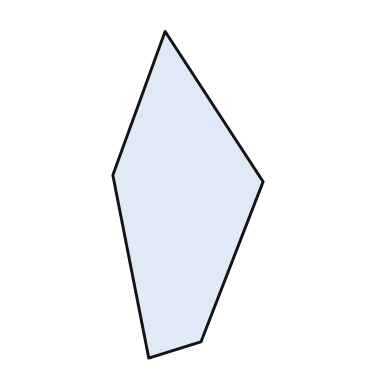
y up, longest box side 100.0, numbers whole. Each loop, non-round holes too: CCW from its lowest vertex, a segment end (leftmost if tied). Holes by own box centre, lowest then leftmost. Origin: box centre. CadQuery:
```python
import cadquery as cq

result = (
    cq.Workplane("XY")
    .moveTo(-12.0, -50.0)
    .lineTo(4.0, -45.0)
    .lineTo(23.0, 4.0)
    .lineTo(-7.0, 50.0)
    .lineTo(-23.0, 6.0)
    .close()
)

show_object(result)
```